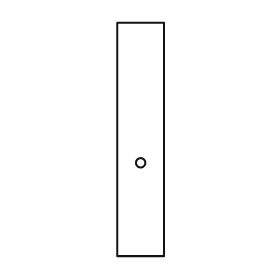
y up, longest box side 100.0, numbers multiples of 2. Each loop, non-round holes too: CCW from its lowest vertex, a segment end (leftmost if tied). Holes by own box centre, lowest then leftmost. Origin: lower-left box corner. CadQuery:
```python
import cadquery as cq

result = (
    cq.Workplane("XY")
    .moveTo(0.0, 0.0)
    .lineTo(20.0, 0.0)
    .lineTo(20.0, 100.0)
    .lineTo(0.0, 100.0)
    .close()
    .moveTo(10.0, 40.0)
    .circle(2.0)
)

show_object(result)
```